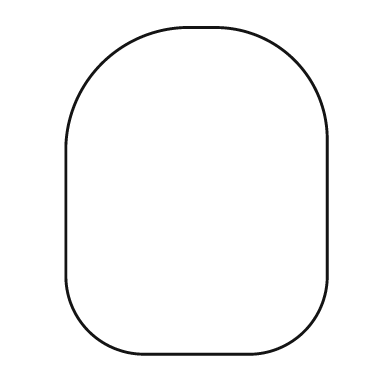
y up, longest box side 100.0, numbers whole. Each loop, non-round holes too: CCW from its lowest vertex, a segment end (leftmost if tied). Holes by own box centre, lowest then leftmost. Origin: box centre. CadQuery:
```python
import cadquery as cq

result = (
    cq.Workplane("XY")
    .moveTo(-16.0, -50.0)
    .lineTo(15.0, -50.0)
    .threePointArc((33.0, -43.0), (40.0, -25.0))
    .lineTo(40.0, 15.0)
    .threePointArc((30.0, 40.0), (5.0, 50.0))
    .lineTo(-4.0, 50.0)
    .threePointArc((-29.0, 39.0), (-40.0, 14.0))
    .lineTo(-40.0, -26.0)
    .threePointArc((-33.0, -43.0), (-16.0, -50.0))
    .close()
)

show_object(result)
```